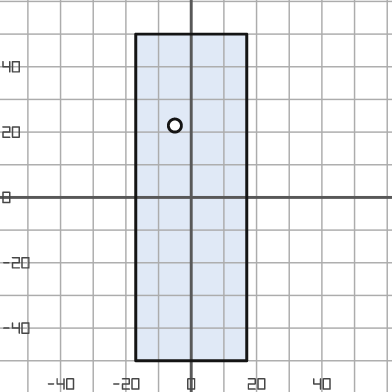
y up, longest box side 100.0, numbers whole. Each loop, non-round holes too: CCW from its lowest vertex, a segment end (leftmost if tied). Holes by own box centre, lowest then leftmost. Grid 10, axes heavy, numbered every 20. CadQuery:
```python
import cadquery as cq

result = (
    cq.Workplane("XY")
    .moveTo(-17.0, -50.0)
    .lineTo(17.0, -50.0)
    .lineTo(17.0, 50.0)
    .lineTo(-17.0, 50.0)
    .close()
    .moveTo(-5.0, 22.0)
    .circle(2.0)
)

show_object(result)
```